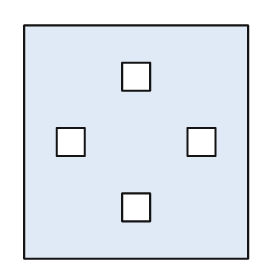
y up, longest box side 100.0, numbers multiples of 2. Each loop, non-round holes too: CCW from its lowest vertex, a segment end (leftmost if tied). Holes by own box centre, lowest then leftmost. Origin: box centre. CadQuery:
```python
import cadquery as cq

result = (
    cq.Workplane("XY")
    .moveTo(-48.0, -50.0)
    .lineTo(48.0, -50.0)
    .lineTo(48.0, 50.0)
    .lineTo(-48.0, 50.0)
    .close()
    .moveTo(-6.0, -34.0)
    .lineTo(6.0, -34.0)
    .lineTo(6.0, -22.0)
    .lineTo(-6.0, -22.0)
    .close()
    .moveTo(-34.0, -6.0)
    .lineTo(-22.0, -6.0)
    .lineTo(-22.0, 6.0)
    .lineTo(-34.0, 6.0)
    .close()
    .moveTo(22.0, -6.0)
    .lineTo(34.0, -6.0)
    .lineTo(34.0, 6.0)
    .lineTo(22.0, 6.0)
    .close()
    .moveTo(-6.0, 22.0)
    .lineTo(6.0, 22.0)
    .lineTo(6.0, 34.0)
    .lineTo(-6.0, 34.0)
    .close()
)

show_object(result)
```